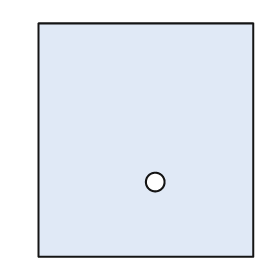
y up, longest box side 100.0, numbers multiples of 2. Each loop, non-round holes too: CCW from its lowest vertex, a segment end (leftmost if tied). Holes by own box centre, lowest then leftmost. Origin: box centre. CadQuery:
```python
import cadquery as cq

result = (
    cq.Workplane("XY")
    .moveTo(-46.0, -50.0)
    .lineTo(46.0, -50.0)
    .lineTo(46.0, 50.0)
    .lineTo(-46.0, 50.0)
    .close()
    .moveTo(4.0, -18.0)
    .circle(4.0)
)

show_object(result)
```